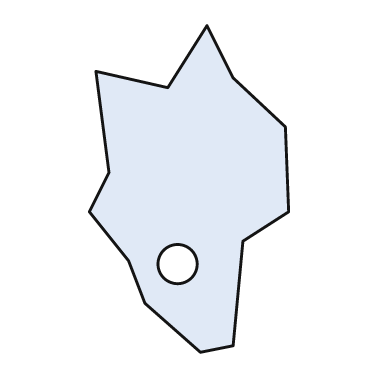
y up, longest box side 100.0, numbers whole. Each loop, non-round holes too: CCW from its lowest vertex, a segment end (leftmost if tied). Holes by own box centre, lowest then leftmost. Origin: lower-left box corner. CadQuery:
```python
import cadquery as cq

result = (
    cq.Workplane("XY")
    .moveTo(34.0, 0.0)
    .lineTo(44.0, 2.0)
    .lineTo(47.0, 34.0)
    .lineTo(61.0, 43.0)
    .lineTo(60.0, 69.0)
    .lineTo(44.0, 84.0)
    .lineTo(36.0, 100.0)
    .lineTo(24.0, 81.0)
    .lineTo(2.0, 86.0)
    .lineTo(6.0, 55.0)
    .lineTo(0.0, 43.0)
    .lineTo(12.0, 28.0)
    .lineTo(17.0, 15.0)
    .close()
    .moveTo(27.0, 27.0)
    .circle(6.0)
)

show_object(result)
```